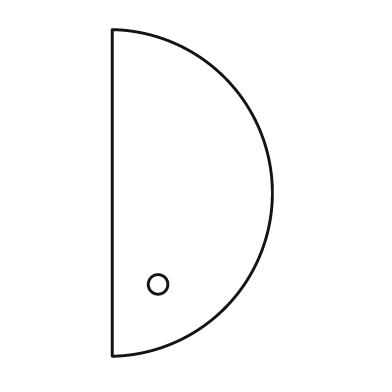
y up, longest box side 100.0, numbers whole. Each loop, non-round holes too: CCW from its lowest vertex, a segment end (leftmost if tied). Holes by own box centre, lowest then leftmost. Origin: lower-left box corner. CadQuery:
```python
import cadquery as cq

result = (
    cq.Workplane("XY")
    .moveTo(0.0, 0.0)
    .threePointArc((49.0, 50.0), (0.0, 100.0))
    .close()
    .moveTo(14.0, 22.0)
    .circle(3.0)
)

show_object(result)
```